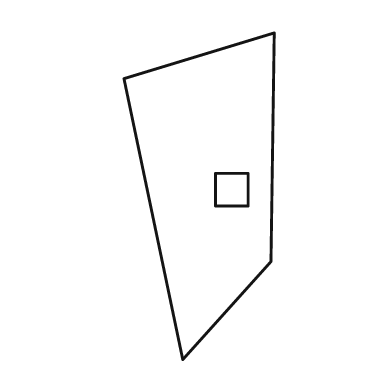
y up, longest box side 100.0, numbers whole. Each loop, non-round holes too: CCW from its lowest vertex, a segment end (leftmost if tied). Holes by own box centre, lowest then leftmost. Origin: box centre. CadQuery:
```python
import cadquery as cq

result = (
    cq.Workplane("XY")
    .moveTo(-5.0, -50.0)
    .lineTo(22.0, -20.0)
    .lineTo(23.0, 50.0)
    .lineTo(-23.0, 36.0)
    .close()
    .moveTo(5.0, -3.0)
    .lineTo(15.0, -3.0)
    .lineTo(15.0, 7.0)
    .lineTo(5.0, 7.0)
    .close()
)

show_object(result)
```